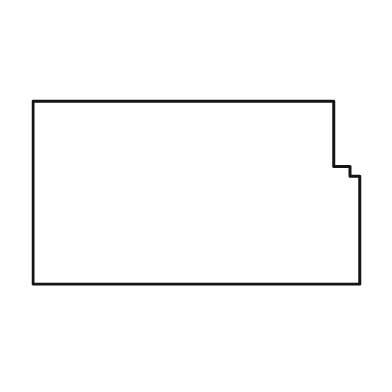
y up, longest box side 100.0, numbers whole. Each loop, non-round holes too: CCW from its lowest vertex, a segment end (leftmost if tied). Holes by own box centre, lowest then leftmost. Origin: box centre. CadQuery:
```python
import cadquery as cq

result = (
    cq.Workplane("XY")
    .moveTo(-50.0, -28.0)
    .lineTo(50.0, -28.0)
    .lineTo(50.0, 5.0)
    .lineTo(47.0, 5.0)
    .lineTo(47.0, 8.0)
    .lineTo(42.0, 8.0)
    .lineTo(42.0, 28.0)
    .lineTo(-50.0, 28.0)
    .close()
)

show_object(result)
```